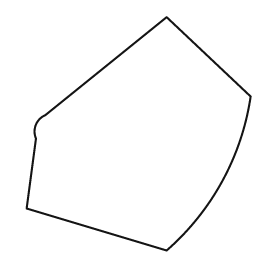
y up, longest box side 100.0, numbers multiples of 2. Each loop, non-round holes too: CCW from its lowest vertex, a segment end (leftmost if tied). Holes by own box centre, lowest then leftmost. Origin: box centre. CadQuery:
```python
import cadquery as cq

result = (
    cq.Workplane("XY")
    .moveTo(12.0, -50.0)
    .threePointArc((36.0, -20.0), (48.0, 16.0))
    .lineTo(12.0, 50.0)
    .lineTo(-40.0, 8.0)
    .threePointArc((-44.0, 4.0), (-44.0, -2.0))
    .lineTo(-48.0, -32.0)
    .close()
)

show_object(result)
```